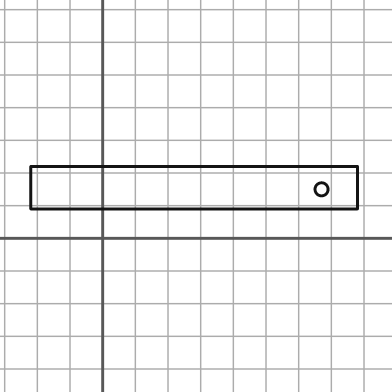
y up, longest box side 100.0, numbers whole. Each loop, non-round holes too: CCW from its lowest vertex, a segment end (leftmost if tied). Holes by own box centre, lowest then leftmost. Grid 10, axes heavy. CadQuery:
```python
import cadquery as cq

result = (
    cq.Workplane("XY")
    .moveTo(-22.0, 9.0)
    .lineTo(78.0, 9.0)
    .lineTo(78.0, 22.0)
    .lineTo(-22.0, 22.0)
    .close()
    .moveTo(67.0, 15.0)
    .circle(2.0)
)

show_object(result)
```